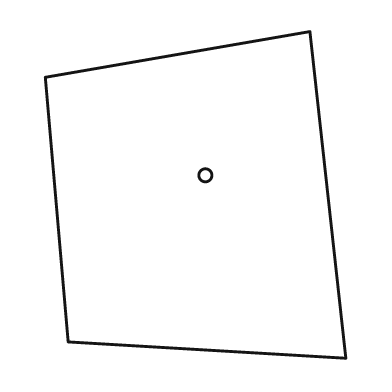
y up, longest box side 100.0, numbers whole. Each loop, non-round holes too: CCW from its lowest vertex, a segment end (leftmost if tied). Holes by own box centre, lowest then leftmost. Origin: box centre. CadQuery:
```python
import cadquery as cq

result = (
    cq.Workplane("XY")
    .moveTo(46.0, -50.0)
    .lineTo(35.0, 50.0)
    .lineTo(-46.0, 36.0)
    .lineTo(-39.0, -45.0)
    .close()
    .moveTo(3.0, 6.0)
    .circle(2.0)
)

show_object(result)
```